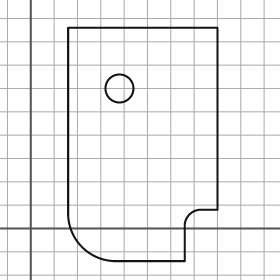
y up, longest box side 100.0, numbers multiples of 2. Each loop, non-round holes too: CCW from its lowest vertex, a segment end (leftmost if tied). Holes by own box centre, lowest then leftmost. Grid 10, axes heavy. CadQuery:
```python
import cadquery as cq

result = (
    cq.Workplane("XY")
    .moveTo(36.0, -14.0)
    .lineTo(66.0, -14.0)
    .lineTo(66.0, 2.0)
    .threePointArc((68.0, 6.0), (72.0, 8.0))
    .lineTo(80.0, 8.0)
    .lineTo(80.0, 86.0)
    .lineTo(16.0, 86.0)
    .lineTo(16.0, 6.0)
    .threePointArc((22.0, -8.0), (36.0, -14.0))
    .close()
    .moveTo(38.0, 60.0)
    .circle(6.0)
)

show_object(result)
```